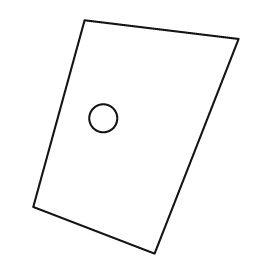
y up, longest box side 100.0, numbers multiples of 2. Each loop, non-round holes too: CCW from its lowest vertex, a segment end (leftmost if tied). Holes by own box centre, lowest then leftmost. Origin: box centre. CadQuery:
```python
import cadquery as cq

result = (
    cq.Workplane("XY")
    .moveTo(8.0, -50.0)
    .lineTo(44.0, 42.0)
    .lineTo(-22.0, 50.0)
    .lineTo(-44.0, -30.0)
    .close()
    .moveTo(-14.0, 8.0)
    .circle(6.0)
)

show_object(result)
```